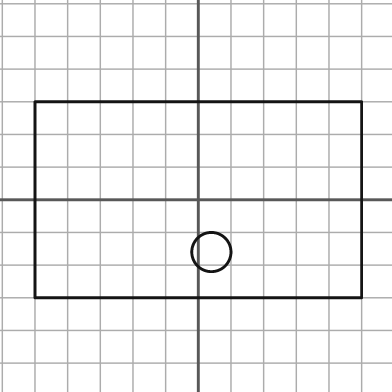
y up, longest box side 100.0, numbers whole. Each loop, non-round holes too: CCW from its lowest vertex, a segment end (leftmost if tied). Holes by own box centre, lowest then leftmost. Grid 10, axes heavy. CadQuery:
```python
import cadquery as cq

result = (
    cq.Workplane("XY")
    .moveTo(-50.0, -30.0)
    .lineTo(50.0, -30.0)
    .lineTo(50.0, 30.0)
    .lineTo(-50.0, 30.0)
    .close()
    .moveTo(4.0, -16.0)
    .circle(6.0)
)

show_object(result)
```